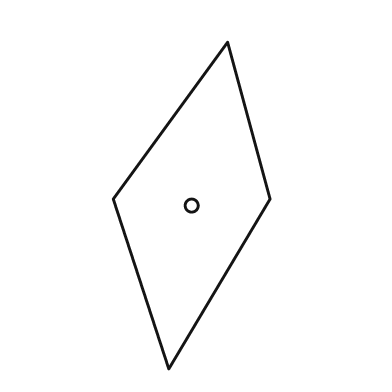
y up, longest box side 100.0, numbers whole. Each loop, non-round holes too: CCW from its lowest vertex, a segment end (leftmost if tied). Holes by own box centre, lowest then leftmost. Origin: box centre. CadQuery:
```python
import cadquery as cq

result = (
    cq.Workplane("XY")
    .moveTo(-7.0, -50.0)
    .lineTo(24.0, 2.0)
    .lineTo(11.0, 50.0)
    .lineTo(-24.0, 2.0)
    .close()
    .moveTo(0.0, 0.0)
    .circle(2.0)
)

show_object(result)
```